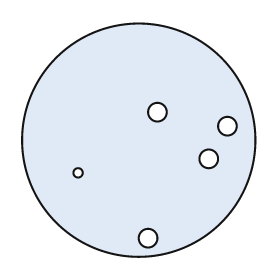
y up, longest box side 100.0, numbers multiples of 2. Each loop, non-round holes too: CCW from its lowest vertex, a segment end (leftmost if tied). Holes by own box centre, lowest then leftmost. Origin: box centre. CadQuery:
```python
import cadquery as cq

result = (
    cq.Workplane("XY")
    .moveTo(0.0, 0.0)
    .circle(50.0)
    .moveTo(4.0, -42.0)
    .circle(4.0)
    .moveTo(-26.0, -14.0)
    .circle(2.0)
    .moveTo(30.0, -8.0)
    .circle(4.0)
    .moveTo(38.0, 6.0)
    .circle(4.0)
    .moveTo(8.0, 12.0)
    .circle(4.0)
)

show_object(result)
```